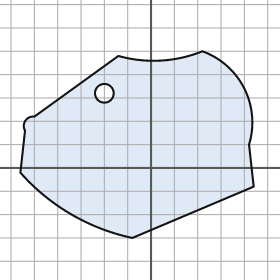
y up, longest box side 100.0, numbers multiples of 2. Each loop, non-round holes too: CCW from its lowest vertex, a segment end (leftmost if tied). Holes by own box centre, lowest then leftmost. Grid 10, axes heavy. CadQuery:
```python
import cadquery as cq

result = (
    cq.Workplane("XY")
    .moveTo(-8.0, -30.0)
    .lineTo(44.0, -8.0)
    .lineTo(42.0, 10.0)
    .threePointArc((40.0, 34.0), (22.0, 50.0))
    .threePointArc((4.0, 46.0), (-14.0, 48.0))
    .lineTo(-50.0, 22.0)
    .threePointArc((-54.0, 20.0), (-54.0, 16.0))
    .lineTo(-56.0, -2.0)
    .threePointArc((-34.0, -20.0), (-8.0, -30.0))
    .close()
    .moveTo(-20.0, 32.0)
    .circle(4.0)
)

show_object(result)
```